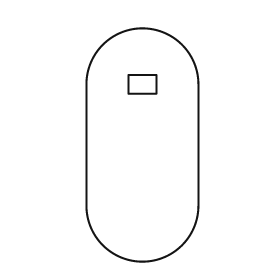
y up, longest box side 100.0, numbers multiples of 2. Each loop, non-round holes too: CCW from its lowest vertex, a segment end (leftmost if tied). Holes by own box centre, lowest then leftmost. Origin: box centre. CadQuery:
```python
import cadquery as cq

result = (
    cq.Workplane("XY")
    .moveTo(-24.0, -26.0)
    .threePointArc((0.0, -50.0), (24.0, -26.0))
    .lineTo(24.0, 26.0)
    .threePointArc((0.0, 50.0), (-24.0, 26.0))
    .close()
    .moveTo(-6.0, 22.0)
    .lineTo(6.0, 22.0)
    .lineTo(6.0, 30.0)
    .lineTo(-6.0, 30.0)
    .close()
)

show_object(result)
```